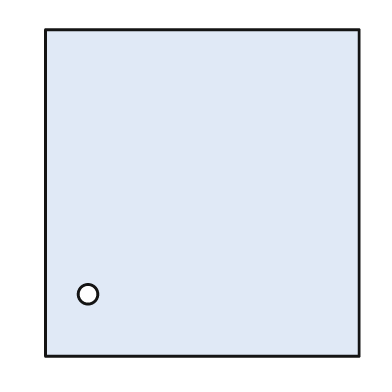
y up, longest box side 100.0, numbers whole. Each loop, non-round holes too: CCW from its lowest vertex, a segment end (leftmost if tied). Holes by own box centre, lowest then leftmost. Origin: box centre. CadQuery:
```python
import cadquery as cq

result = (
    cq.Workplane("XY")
    .moveTo(-48.0, -50.0)
    .lineTo(48.0, -50.0)
    .lineTo(48.0, 50.0)
    .lineTo(-48.0, 50.0)
    .close()
    .moveTo(-35.0, -31.0)
    .circle(3.0)
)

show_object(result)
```